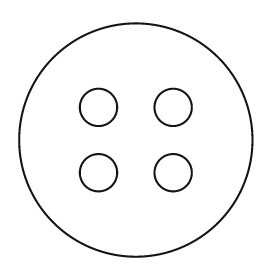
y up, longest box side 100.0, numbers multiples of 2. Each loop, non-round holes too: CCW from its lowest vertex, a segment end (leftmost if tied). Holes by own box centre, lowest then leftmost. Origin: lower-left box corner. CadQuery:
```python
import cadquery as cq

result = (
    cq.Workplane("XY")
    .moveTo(50.0, 50.0)
    .circle(50.0)
    .moveTo(34.0, 36.0)
    .circle(8.0)
    .moveTo(66.0, 36.0)
    .circle(8.0)
    .moveTo(34.0, 64.0)
    .circle(8.0)
    .moveTo(66.0, 64.0)
    .circle(8.0)
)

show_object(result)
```